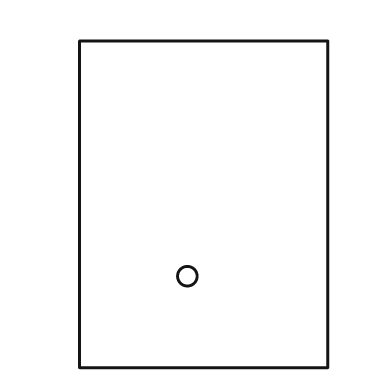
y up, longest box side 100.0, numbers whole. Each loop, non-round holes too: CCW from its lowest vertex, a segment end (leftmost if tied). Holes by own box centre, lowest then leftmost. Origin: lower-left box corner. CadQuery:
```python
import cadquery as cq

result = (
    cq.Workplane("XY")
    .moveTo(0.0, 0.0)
    .lineTo(76.0, 0.0)
    .lineTo(76.0, 100.0)
    .lineTo(0.0, 100.0)
    .close()
    .moveTo(33.0, 28.0)
    .circle(3.0)
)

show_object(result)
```